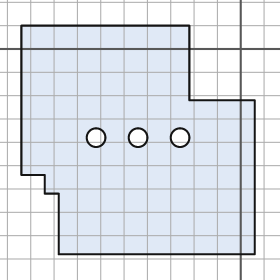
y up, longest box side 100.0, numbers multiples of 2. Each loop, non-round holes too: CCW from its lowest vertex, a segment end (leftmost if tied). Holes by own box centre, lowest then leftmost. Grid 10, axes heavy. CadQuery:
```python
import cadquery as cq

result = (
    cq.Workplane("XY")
    .moveTo(-78.0, -88.0)
    .lineTo(6.0, -88.0)
    .lineTo(6.0, -22.0)
    .lineTo(-22.0, -22.0)
    .lineTo(-22.0, 10.0)
    .lineTo(-94.0, 10.0)
    .lineTo(-94.0, -54.0)
    .lineTo(-84.0, -54.0)
    .lineTo(-84.0, -62.0)
    .lineTo(-78.0, -62.0)
    .close()
    .moveTo(-62.0, -38.0)
    .circle(4.0)
    .moveTo(-44.0, -38.0)
    .circle(4.0)
    .moveTo(-26.0, -38.0)
    .circle(4.0)
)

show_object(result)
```